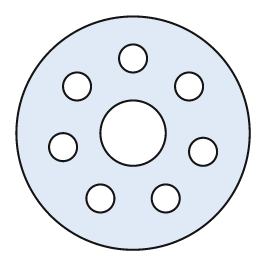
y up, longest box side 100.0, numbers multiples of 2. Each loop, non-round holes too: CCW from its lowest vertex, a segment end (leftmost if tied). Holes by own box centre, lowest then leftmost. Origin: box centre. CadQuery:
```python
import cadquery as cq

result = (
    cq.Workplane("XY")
    .moveTo(0.0, 0.0)
    .circle(50.0)
    .moveTo(-14.0, -28.0)
    .circle(6.0)
    .moveTo(14.0, -28.0)
    .circle(6.0)
    .moveTo(30.0, -8.0)
    .circle(6.0)
    .moveTo(-30.0, -6.0)
    .circle(6.0)
    .moveTo(0.0, 0.0)
    .circle(14.0)
    .moveTo(-24.0, 20.0)
    .circle(6.0)
    .moveTo(24.0, 20.0)
    .circle(6.0)
    .moveTo(0.0, 32.0)
    .circle(6.0)
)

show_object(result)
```